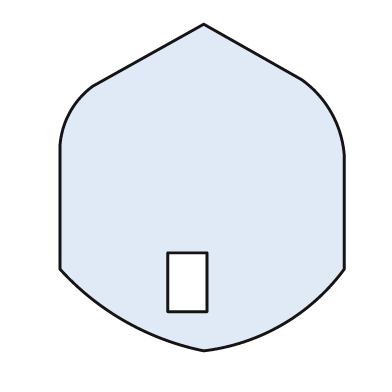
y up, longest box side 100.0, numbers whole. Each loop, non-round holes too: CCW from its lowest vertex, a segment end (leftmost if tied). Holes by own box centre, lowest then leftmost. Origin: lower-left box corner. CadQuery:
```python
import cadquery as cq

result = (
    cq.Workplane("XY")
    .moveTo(44.0, 0.0)
    .threePointArc((68.0, 8.0), (87.0, 25.0))
    .lineTo(87.0, 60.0)
    .threePointArc((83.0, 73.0), (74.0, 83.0))
    .lineTo(44.0, 100.0)
    .lineTo(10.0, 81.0)
    .threePointArc((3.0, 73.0), (0.0, 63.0))
    .lineTo(0.0, 25.0)
    .threePointArc((20.0, 9.0), (44.0, 0.0))
    .close()
    .moveTo(33.0, 12.0)
    .lineTo(45.0, 12.0)
    .lineTo(45.0, 30.0)
    .lineTo(33.0, 30.0)
    .close()
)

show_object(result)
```